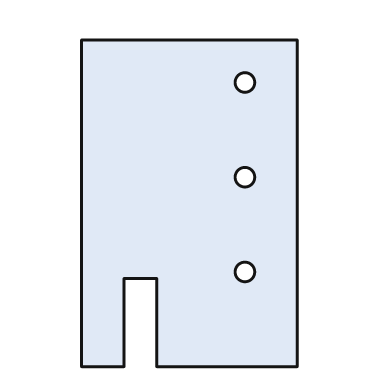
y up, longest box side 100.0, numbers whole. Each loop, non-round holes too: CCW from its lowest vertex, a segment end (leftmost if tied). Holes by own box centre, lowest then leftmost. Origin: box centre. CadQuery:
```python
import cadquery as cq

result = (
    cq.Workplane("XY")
    .moveTo(-33.0, -50.0)
    .lineTo(-20.0, -50.0)
    .lineTo(-20.0, -23.0)
    .lineTo(-10.0, -23.0)
    .lineTo(-10.0, -50.0)
    .lineTo(33.0, -50.0)
    .lineTo(33.0, 50.0)
    .lineTo(-33.0, 50.0)
    .close()
    .moveTo(17.0, -21.0)
    .circle(3.0)
    .moveTo(17.0, 8.0)
    .circle(3.0)
    .moveTo(17.0, 37.0)
    .circle(3.0)
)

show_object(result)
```